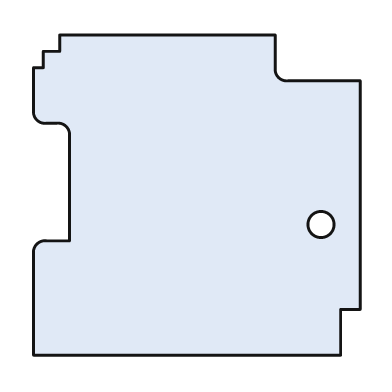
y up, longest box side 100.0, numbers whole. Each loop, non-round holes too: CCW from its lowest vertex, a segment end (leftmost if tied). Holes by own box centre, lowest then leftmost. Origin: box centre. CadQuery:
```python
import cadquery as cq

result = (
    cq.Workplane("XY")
    .moveTo(-50.0, -49.0)
    .lineTo(44.0, -49.0)
    .lineTo(44.0, -35.0)
    .lineTo(50.0, -35.0)
    .lineTo(50.0, 35.0)
    .lineTo(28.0, 35.0)
    .threePointArc((25.0, 36.0), (24.0, 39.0))
    .lineTo(24.0, 49.0)
    .lineTo(-42.0, 49.0)
    .lineTo(-42.0, 44.0)
    .lineTo(-47.0, 44.0)
    .lineTo(-47.0, 39.0)
    .lineTo(-50.0, 39.0)
    .lineTo(-50.0, 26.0)
    .threePointArc((-49.0, 23.0), (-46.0, 22.0))
    .lineTo(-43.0, 22.0)
    .threePointArc((-40.0, 21.0), (-39.0, 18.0))
    .lineTo(-39.0, -14.0)
    .lineTo(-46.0, -14.0)
    .threePointArc((-49.0, -15.0), (-50.0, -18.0))
    .close()
    .moveTo(38.0, -9.0)
    .circle(4.0)
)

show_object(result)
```